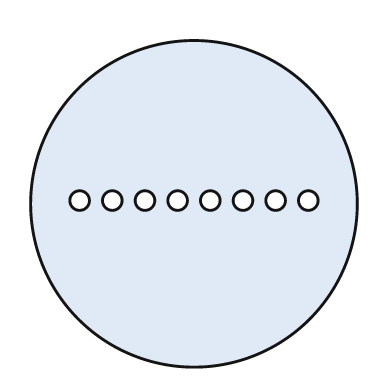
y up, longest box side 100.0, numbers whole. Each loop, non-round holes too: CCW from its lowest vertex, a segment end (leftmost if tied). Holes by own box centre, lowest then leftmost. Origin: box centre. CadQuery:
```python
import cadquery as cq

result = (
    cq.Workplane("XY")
    .moveTo(0.0, 0.0)
    .circle(50.0)
    .moveTo(-35.0, 1.0)
    .circle(3.0)
    .moveTo(-25.0, 1.0)
    .circle(3.0)
    .moveTo(-15.0, 1.0)
    .circle(3.0)
    .moveTo(-5.0, 1.0)
    .circle(3.0)
    .moveTo(5.0, 1.0)
    .circle(3.0)
    .moveTo(15.0, 1.0)
    .circle(3.0)
    .moveTo(25.0, 1.0)
    .circle(3.0)
    .moveTo(35.0, 1.0)
    .circle(3.0)
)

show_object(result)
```